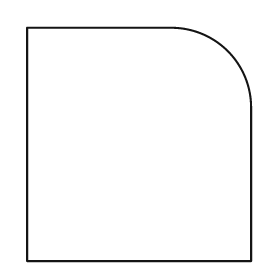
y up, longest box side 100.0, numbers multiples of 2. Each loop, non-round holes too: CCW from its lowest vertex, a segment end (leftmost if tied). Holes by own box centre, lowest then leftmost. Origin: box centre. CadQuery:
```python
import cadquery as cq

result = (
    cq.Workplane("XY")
    .moveTo(-48.0, -50.0)
    .lineTo(48.0, -50.0)
    .lineTo(48.0, 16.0)
    .threePointArc((38.0, 40.0), (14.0, 50.0))
    .lineTo(-48.0, 50.0)
    .close()
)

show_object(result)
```